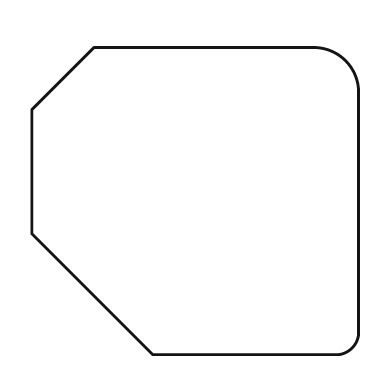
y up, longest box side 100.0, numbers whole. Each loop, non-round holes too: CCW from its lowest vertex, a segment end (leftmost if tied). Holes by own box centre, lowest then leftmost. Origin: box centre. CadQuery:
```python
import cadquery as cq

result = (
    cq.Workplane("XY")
    .moveTo(-13.0, -47.0)
    .lineTo(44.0, -47.0)
    .threePointArc((48.0, -45.0), (50.0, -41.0))
    .lineTo(50.0, 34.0)
    .threePointArc((46.0, 43.0), (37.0, 47.0))
    .lineTo(-31.0, 47.0)
    .lineTo(-50.0, 28.0)
    .lineTo(-50.0, -10.0)
    .close()
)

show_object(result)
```